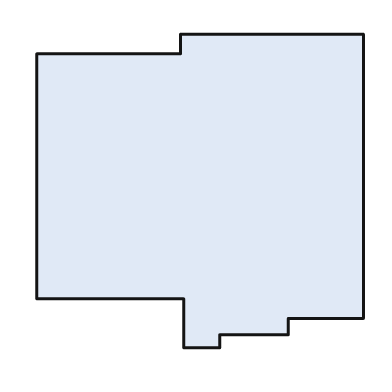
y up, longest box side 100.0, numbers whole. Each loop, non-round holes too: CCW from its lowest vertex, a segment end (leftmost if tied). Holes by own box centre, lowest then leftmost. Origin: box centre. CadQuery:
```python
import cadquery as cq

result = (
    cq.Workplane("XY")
    .moveTo(-5.0, -48.0)
    .lineTo(6.0, -48.0)
    .lineTo(6.0, -44.0)
    .lineTo(27.0, -44.0)
    .lineTo(27.0, -39.0)
    .lineTo(50.0, -39.0)
    .lineTo(50.0, 48.0)
    .lineTo(-6.0, 48.0)
    .lineTo(-6.0, 42.0)
    .lineTo(-50.0, 42.0)
    .lineTo(-50.0, -33.0)
    .lineTo(-5.0, -33.0)
    .close()
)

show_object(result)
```